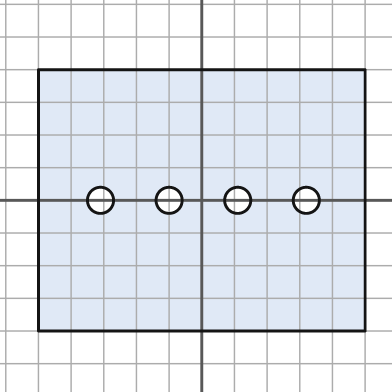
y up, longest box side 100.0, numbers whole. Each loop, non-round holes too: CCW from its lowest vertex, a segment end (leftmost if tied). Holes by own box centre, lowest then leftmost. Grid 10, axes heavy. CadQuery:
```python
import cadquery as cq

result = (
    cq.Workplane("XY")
    .moveTo(-50.0, -40.0)
    .lineTo(50.0, -40.0)
    .lineTo(50.0, 40.0)
    .lineTo(-50.0, 40.0)
    .close()
    .moveTo(-31.0, 0.0)
    .circle(4.0)
    .moveTo(-10.0, 0.0)
    .circle(4.0)
    .moveTo(11.0, 0.0)
    .circle(4.0)
    .moveTo(32.0, 0.0)
    .circle(4.0)
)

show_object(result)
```